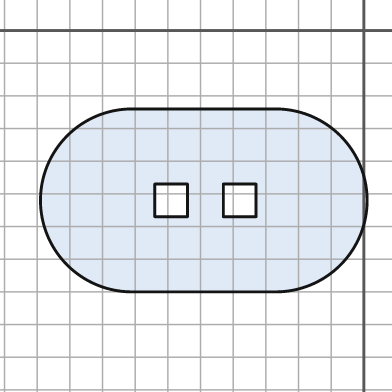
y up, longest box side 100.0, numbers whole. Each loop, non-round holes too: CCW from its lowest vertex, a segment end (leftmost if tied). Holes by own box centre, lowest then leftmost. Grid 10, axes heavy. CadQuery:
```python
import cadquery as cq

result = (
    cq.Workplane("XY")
    .moveTo(-71.0, -80.0)
    .lineTo(-27.0, -80.0)
    .threePointArc((1.0, -52.0), (-27.0, -24.0))
    .lineTo(-71.0, -24.0)
    .threePointArc((-99.0, -52.0), (-71.0, -80.0))
    .close()
    .moveTo(-64.0, -57.0)
    .lineTo(-54.0, -57.0)
    .lineTo(-54.0, -47.0)
    .lineTo(-64.0, -47.0)
    .close()
    .moveTo(-43.0, -57.0)
    .lineTo(-33.0, -57.0)
    .lineTo(-33.0, -47.0)
    .lineTo(-43.0, -47.0)
    .close()
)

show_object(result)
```